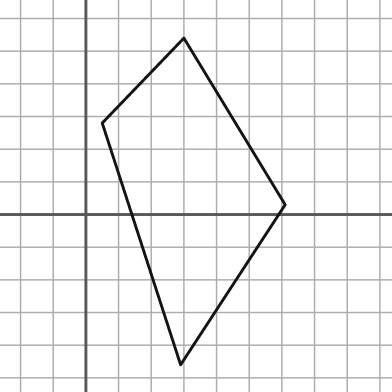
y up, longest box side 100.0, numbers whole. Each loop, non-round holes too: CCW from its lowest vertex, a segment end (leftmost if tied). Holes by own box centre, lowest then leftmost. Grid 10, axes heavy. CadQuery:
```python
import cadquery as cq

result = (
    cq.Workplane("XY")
    .moveTo(29.0, -46.0)
    .lineTo(61.0, 3.0)
    .lineTo(30.0, 54.0)
    .lineTo(5.0, 28.0)
    .close()
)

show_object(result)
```